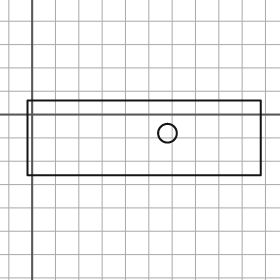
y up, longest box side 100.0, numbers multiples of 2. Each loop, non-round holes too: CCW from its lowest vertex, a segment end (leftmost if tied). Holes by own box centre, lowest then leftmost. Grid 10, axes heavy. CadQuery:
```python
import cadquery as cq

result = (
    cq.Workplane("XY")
    .moveTo(-2.0, -26.0)
    .lineTo(98.0, -26.0)
    .lineTo(98.0, 6.0)
    .lineTo(-2.0, 6.0)
    .close()
    .moveTo(58.0, -8.0)
    .circle(4.0)
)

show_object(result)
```